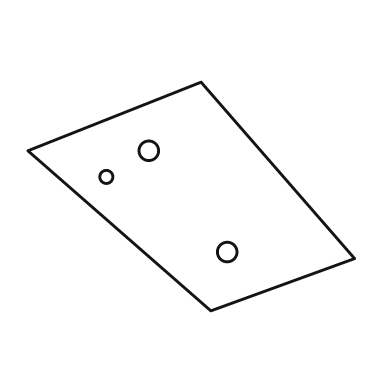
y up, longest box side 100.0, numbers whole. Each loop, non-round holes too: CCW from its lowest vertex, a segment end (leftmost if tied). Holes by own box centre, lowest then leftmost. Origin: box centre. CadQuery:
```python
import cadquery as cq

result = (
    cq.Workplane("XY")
    .moveTo(6.0, -35.0)
    .lineTo(50.0, -19.0)
    .lineTo(3.0, 35.0)
    .lineTo(-50.0, 14.0)
    .close()
    .moveTo(11.0, -17.0)
    .circle(3.0)
    .moveTo(-26.0, 6.0)
    .circle(2.0)
    .moveTo(-13.0, 14.0)
    .circle(3.0)
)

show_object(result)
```